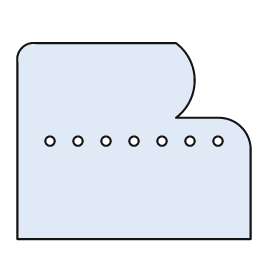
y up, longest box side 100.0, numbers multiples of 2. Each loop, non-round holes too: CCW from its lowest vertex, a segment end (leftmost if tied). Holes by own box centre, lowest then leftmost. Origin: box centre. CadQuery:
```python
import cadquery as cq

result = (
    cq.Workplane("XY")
    .moveTo(-50.0, -42.0)
    .lineTo(50.0, -42.0)
    .lineTo(50.0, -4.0)
    .threePointArc((46.0, 6.0), (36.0, 10.0))
    .lineTo(18.0, 10.0)
    .threePointArc((26.0, 26.0), (18.0, 42.0))
    .lineTo(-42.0, 42.0)
    .threePointArc((-48.0, 40.0), (-50.0, 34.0))
    .close()
    .moveTo(-36.0, 0.0)
    .circle(2.0)
    .moveTo(-24.0, 0.0)
    .circle(2.0)
    .moveTo(-12.0, 0.0)
    .circle(2.0)
    .moveTo(0.0, 0.0)
    .circle(2.0)
    .moveTo(12.0, 0.0)
    .circle(2.0)
    .moveTo(24.0, 0.0)
    .circle(2.0)
    .moveTo(36.0, 0.0)
    .circle(2.0)
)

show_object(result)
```